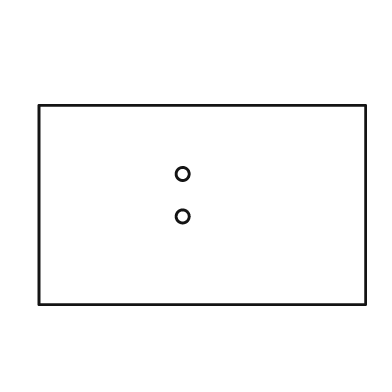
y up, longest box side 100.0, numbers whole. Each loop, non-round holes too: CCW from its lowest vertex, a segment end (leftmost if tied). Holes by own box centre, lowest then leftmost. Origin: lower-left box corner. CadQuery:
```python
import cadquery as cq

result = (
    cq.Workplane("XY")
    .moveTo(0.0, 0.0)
    .lineTo(100.0, 0.0)
    .lineTo(100.0, 61.0)
    .lineTo(0.0, 61.0)
    .close()
    .moveTo(44.0, 27.0)
    .circle(2.0)
    .moveTo(44.0, 40.0)
    .circle(2.0)
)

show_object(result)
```